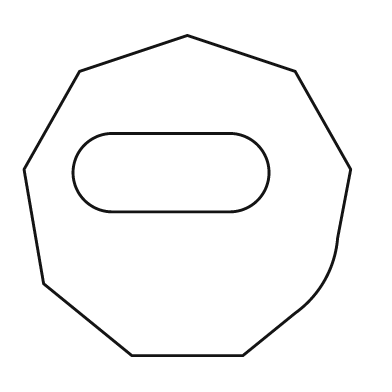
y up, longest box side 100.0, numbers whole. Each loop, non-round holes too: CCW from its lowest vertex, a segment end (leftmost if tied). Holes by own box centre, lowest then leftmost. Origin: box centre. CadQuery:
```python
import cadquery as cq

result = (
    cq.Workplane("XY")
    .moveTo(-17.0, -49.0)
    .lineTo(17.0, -49.0)
    .lineTo(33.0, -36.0)
    .threePointArc((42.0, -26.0), (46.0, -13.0))
    .lineTo(50.0, 8.0)
    .lineTo(33.0, 38.0)
    .lineTo(0.0, 49.0)
    .lineTo(-33.0, 38.0)
    .lineTo(-50.0, 8.0)
    .lineTo(-44.0, -27.0)
    .close()
    .moveTo(-23.0, -5.0)
    .lineTo(13.0, -5.0)
    .threePointArc((25.0, 7.0), (13.0, 19.0))
    .lineTo(-23.0, 19.0)
    .threePointArc((-35.0, 7.0), (-23.0, -5.0))
    .close()
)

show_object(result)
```